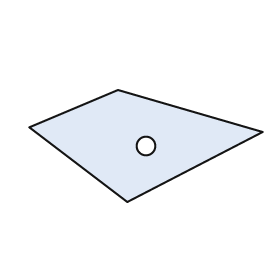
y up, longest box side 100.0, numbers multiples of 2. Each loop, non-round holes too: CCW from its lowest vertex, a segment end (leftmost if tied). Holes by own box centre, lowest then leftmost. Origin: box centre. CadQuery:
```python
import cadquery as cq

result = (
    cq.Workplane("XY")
    .moveTo(-8.0, -24.0)
    .lineTo(50.0, 6.0)
    .lineTo(-12.0, 24.0)
    .lineTo(-50.0, 8.0)
    .close()
    .moveTo(0.0, 0.0)
    .circle(4.0)
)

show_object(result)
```